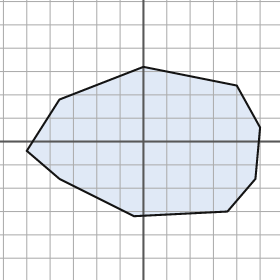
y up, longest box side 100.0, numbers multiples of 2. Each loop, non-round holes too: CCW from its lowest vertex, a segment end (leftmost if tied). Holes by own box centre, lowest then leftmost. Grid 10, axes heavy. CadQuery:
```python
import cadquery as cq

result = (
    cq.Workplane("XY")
    .moveTo(-4.0, -32.0)
    .lineTo(36.0, -30.0)
    .lineTo(48.0, -16.0)
    .lineTo(50.0, 6.0)
    .lineTo(40.0, 24.0)
    .lineTo(0.0, 32.0)
    .lineTo(-36.0, 18.0)
    .lineTo(-50.0, -4.0)
    .lineTo(-36.0, -16.0)
    .close()
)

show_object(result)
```